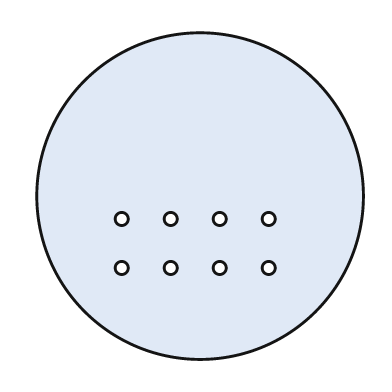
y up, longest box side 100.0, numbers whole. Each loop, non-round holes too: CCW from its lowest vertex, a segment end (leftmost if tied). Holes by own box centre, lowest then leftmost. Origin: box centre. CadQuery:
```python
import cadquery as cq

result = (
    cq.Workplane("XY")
    .moveTo(0.0, 0.0)
    .circle(50.0)
    .moveTo(-24.0, -22.0)
    .circle(2.0)
    .moveTo(-9.0, -22.0)
    .circle(2.0)
    .moveTo(6.0, -22.0)
    .circle(2.0)
    .moveTo(21.0, -22.0)
    .circle(2.0)
    .moveTo(-24.0, -7.0)
    .circle(2.0)
    .moveTo(-9.0, -7.0)
    .circle(2.0)
    .moveTo(6.0, -7.0)
    .circle(2.0)
    .moveTo(21.0, -7.0)
    .circle(2.0)
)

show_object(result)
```